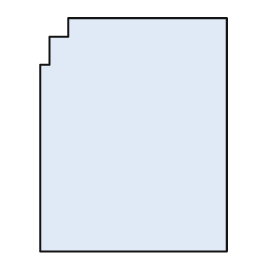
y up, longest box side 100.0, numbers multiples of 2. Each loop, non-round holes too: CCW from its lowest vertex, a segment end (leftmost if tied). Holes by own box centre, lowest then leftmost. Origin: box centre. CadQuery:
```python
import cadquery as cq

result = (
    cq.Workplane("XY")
    .moveTo(-40.0, -50.0)
    .lineTo(40.0, -50.0)
    .lineTo(40.0, 50.0)
    .lineTo(-28.0, 50.0)
    .lineTo(-28.0, 42.0)
    .lineTo(-36.0, 42.0)
    .lineTo(-36.0, 30.0)
    .lineTo(-40.0, 30.0)
    .close()
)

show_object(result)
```